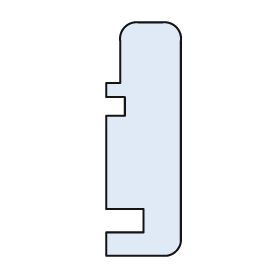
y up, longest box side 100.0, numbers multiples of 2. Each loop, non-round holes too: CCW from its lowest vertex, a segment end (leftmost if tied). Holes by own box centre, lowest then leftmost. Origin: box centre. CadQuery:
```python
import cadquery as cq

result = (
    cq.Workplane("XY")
    .moveTo(-16.0, -50.0)
    .lineTo(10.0, -50.0)
    .threePointArc((14.0, -48.0), (16.0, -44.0))
    .lineTo(16.0, 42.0)
    .threePointArc((14.0, 48.0), (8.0, 50.0))
    .lineTo(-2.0, 50.0)
    .threePointArc((-8.0, 48.0), (-10.0, 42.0))
    .lineTo(-10.0, 24.0)
    .lineTo(-16.0, 24.0)
    .lineTo(-16.0, 18.0)
    .lineTo(-8.0, 18.0)
    .lineTo(-8.0, 10.0)
    .lineTo(-16.0, 10.0)
    .lineTo(-16.0, -30.0)
    .lineTo(0.0, -30.0)
    .lineTo(0.0, -40.0)
    .lineTo(-16.0, -40.0)
    .close()
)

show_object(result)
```